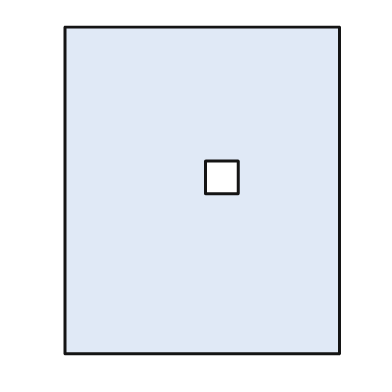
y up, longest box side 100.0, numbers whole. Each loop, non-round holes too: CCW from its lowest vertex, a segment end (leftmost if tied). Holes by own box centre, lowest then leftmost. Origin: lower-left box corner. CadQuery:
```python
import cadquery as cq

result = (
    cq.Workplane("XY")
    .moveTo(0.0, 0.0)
    .lineTo(84.0, 0.0)
    .lineTo(84.0, 100.0)
    .lineTo(0.0, 100.0)
    .close()
    .moveTo(43.0, 49.0)
    .lineTo(53.0, 49.0)
    .lineTo(53.0, 59.0)
    .lineTo(43.0, 59.0)
    .close()
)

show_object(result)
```